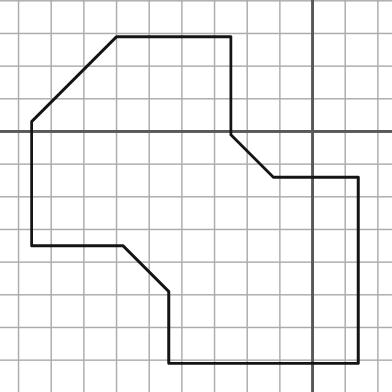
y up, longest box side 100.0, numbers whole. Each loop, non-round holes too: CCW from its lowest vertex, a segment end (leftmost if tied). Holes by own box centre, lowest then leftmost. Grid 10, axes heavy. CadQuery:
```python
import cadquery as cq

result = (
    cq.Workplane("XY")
    .moveTo(-44.0, -71.0)
    .lineTo(14.0, -71.0)
    .lineTo(14.0, -14.0)
    .lineTo(-12.0, -14.0)
    .lineTo(-25.0, -1.0)
    .lineTo(-25.0, 29.0)
    .lineTo(-60.0, 29.0)
    .lineTo(-86.0, 3.0)
    .lineTo(-86.0, -35.0)
    .lineTo(-58.0, -35.0)
    .lineTo(-44.0, -49.0)
    .close()
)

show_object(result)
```